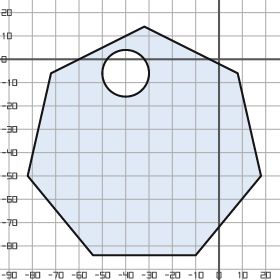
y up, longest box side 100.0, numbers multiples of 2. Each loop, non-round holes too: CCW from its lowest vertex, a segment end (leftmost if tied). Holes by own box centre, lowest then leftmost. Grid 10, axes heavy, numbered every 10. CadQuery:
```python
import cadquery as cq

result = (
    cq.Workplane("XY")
    .moveTo(-54.0, -84.0)
    .lineTo(-10.0, -84.0)
    .lineTo(18.0, -50.0)
    .lineTo(8.0, -6.0)
    .lineTo(-32.0, 14.0)
    .lineTo(-72.0, -6.0)
    .lineTo(-82.0, -50.0)
    .close()
    .moveTo(-40.0, -6.0)
    .circle(10.0)
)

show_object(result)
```